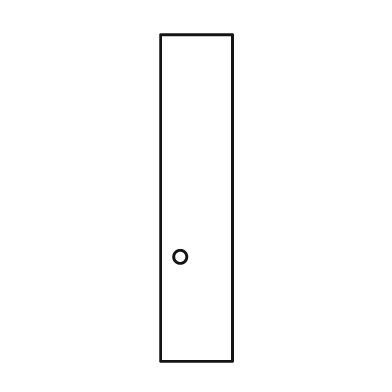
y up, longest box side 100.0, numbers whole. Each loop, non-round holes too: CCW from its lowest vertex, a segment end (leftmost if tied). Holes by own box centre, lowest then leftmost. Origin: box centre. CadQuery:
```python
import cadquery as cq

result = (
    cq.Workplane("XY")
    .moveTo(-11.0, -50.0)
    .lineTo(11.0, -50.0)
    .lineTo(11.0, 50.0)
    .lineTo(-11.0, 50.0)
    .close()
    .moveTo(-5.0, -18.0)
    .circle(2.0)
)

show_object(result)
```